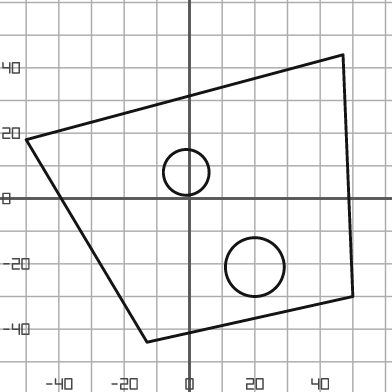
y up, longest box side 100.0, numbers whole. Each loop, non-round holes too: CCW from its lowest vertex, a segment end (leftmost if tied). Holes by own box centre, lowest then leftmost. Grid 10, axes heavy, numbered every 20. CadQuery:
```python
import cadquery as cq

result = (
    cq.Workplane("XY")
    .moveTo(-13.0, -44.0)
    .lineTo(50.0, -30.0)
    .lineTo(47.0, 44.0)
    .lineTo(-50.0, 18.0)
    .close()
    .moveTo(20.0, -21.0)
    .circle(9.0)
    .moveTo(-1.0, 8.0)
    .circle(7.0)
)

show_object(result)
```